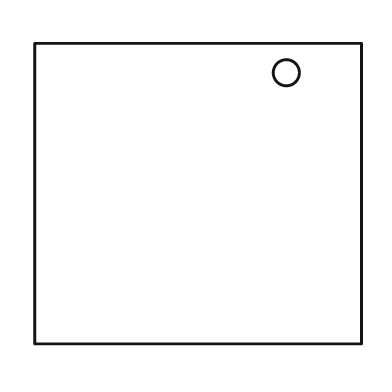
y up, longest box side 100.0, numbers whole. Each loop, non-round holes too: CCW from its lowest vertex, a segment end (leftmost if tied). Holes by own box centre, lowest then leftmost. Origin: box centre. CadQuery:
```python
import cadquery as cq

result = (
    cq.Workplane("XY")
    .moveTo(-50.0, -46.0)
    .lineTo(50.0, -46.0)
    .lineTo(50.0, 46.0)
    .lineTo(-50.0, 46.0)
    .close()
    .moveTo(27.0, 37.0)
    .circle(4.0)
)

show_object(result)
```